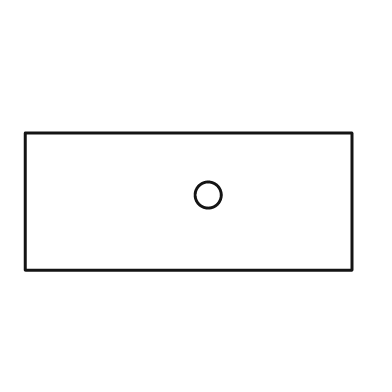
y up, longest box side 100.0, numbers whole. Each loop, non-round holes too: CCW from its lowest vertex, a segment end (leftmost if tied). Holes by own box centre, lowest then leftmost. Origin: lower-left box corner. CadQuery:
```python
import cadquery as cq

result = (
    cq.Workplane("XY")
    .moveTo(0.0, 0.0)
    .lineTo(100.0, 0.0)
    .lineTo(100.0, 42.0)
    .lineTo(0.0, 42.0)
    .close()
    .moveTo(56.0, 23.0)
    .circle(4.0)
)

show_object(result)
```